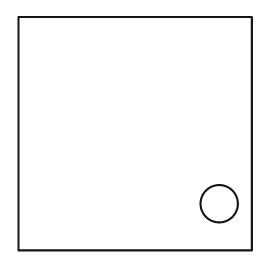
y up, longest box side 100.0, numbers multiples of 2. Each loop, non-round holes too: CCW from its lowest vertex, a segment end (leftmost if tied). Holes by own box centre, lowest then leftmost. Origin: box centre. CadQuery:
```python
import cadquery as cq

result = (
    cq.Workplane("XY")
    .moveTo(-50.0, -50.0)
    .lineTo(50.0, -50.0)
    .lineTo(50.0, 50.0)
    .lineTo(-50.0, 50.0)
    .close()
    .moveTo(36.0, -30.0)
    .circle(8.0)
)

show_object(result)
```